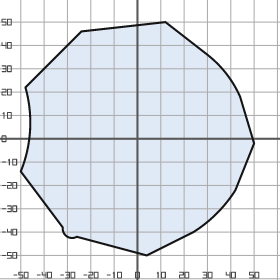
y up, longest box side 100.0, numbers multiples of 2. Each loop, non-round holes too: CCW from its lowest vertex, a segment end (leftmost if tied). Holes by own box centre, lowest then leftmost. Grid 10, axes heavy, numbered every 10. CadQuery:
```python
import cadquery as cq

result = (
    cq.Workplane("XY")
    .moveTo(4.0, -50.0)
    .lineTo(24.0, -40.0)
    .threePointArc((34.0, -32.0), (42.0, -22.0))
    .lineTo(50.0, -2.0)
    .lineTo(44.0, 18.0)
    .threePointArc((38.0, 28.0), (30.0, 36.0))
    .lineTo(12.0, 50.0)
    .lineTo(-24.0, 46.0)
    .lineTo(-48.0, 22.0)
    .threePointArc((-46.0, 4.0), (-50.0, -14.0))
    .lineTo(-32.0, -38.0)
    .threePointArc((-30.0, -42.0), (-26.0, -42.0))
    .close()
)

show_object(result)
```